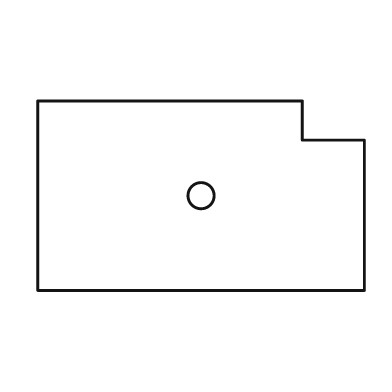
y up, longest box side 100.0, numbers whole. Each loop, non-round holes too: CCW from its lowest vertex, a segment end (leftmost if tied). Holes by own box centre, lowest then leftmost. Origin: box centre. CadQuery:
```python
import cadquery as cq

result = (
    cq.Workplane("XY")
    .moveTo(-50.0, -29.0)
    .lineTo(50.0, -29.0)
    .lineTo(50.0, 17.0)
    .lineTo(31.0, 17.0)
    .lineTo(31.0, 29.0)
    .lineTo(-50.0, 29.0)
    .close()
    .moveTo(0.0, 0.0)
    .circle(4.0)
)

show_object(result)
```